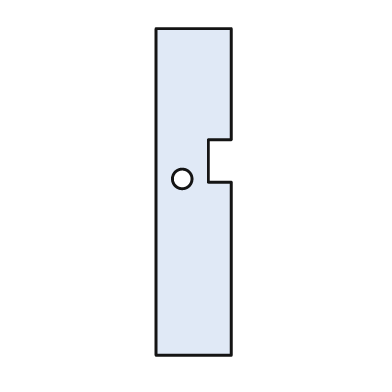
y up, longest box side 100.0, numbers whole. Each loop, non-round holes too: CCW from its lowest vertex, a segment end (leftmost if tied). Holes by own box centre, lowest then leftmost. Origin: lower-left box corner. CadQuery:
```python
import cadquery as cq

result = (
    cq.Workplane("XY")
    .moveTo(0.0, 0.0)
    .lineTo(23.0, 0.0)
    .lineTo(23.0, 53.0)
    .lineTo(16.0, 53.0)
    .lineTo(16.0, 66.0)
    .lineTo(23.0, 66.0)
    .lineTo(23.0, 100.0)
    .lineTo(0.0, 100.0)
    .close()
    .moveTo(8.0, 54.0)
    .circle(3.0)
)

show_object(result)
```